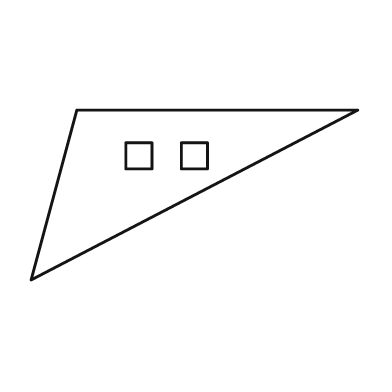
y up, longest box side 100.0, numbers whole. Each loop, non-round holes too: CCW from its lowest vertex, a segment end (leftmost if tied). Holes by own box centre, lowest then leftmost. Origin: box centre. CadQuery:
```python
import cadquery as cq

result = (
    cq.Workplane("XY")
    .moveTo(-50.0, -26.0)
    .lineTo(50.0, 26.0)
    .lineTo(-36.0, 26.0)
    .close()
    .moveTo(-21.0, 8.0)
    .lineTo(-13.0, 8.0)
    .lineTo(-13.0, 16.0)
    .lineTo(-21.0, 16.0)
    .close()
    .moveTo(-4.0, 8.0)
    .lineTo(4.0, 8.0)
    .lineTo(4.0, 16.0)
    .lineTo(-4.0, 16.0)
    .close()
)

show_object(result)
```